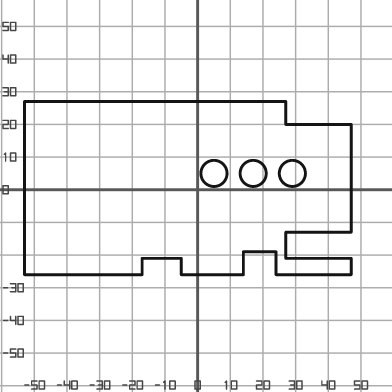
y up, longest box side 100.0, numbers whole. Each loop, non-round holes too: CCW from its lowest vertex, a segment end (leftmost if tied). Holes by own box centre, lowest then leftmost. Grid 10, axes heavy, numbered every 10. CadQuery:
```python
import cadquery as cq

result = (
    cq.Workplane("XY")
    .moveTo(-53.0, -26.0)
    .lineTo(-17.0, -26.0)
    .lineTo(-17.0, -21.0)
    .lineTo(-5.0, -21.0)
    .lineTo(-5.0, -26.0)
    .lineTo(14.0, -26.0)
    .lineTo(14.0, -19.0)
    .lineTo(24.0, -19.0)
    .lineTo(24.0, -26.0)
    .lineTo(47.0, -26.0)
    .lineTo(47.0, -21.0)
    .lineTo(27.0, -21.0)
    .lineTo(27.0, -13.0)
    .lineTo(47.0, -13.0)
    .lineTo(47.0, 20.0)
    .lineTo(27.0, 20.0)
    .lineTo(27.0, 27.0)
    .lineTo(-53.0, 27.0)
    .close()
    .moveTo(5.0, 5.0)
    .circle(4.0)
    .moveTo(17.0, 5.0)
    .circle(4.0)
    .moveTo(29.0, 5.0)
    .circle(4.0)
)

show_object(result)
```